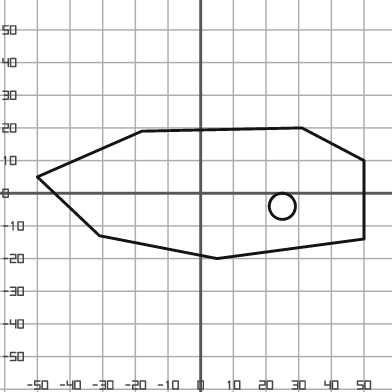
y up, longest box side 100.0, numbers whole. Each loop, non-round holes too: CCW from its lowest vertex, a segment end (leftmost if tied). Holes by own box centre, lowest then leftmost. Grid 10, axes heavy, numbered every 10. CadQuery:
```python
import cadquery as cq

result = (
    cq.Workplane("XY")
    .moveTo(5.0, -20.0)
    .lineTo(50.0, -14.0)
    .lineTo(50.0, 10.0)
    .lineTo(31.0, 20.0)
    .lineTo(-18.0, 19.0)
    .lineTo(-50.0, 5.0)
    .lineTo(-31.0, -13.0)
    .close()
    .moveTo(25.0, -4.0)
    .circle(4.0)
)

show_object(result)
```